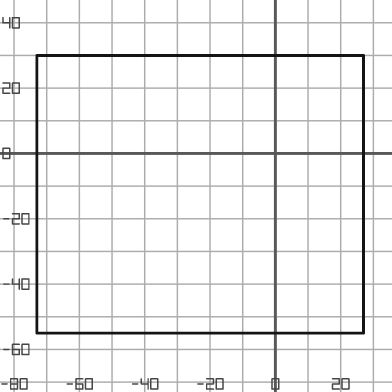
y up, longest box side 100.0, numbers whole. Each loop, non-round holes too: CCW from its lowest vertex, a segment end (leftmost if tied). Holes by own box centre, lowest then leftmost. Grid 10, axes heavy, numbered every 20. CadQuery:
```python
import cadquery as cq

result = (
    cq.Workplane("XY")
    .moveTo(-73.0, -55.0)
    .lineTo(27.0, -55.0)
    .lineTo(27.0, 30.0)
    .lineTo(-73.0, 30.0)
    .close()
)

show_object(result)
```